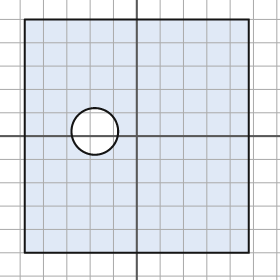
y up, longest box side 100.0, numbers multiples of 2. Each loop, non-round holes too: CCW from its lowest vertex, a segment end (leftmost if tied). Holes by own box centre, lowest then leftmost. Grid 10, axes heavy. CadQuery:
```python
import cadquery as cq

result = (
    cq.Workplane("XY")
    .moveTo(-48.0, -50.0)
    .lineTo(48.0, -50.0)
    .lineTo(48.0, 50.0)
    .lineTo(-48.0, 50.0)
    .close()
    .moveTo(-18.0, 2.0)
    .circle(10.0)
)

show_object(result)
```